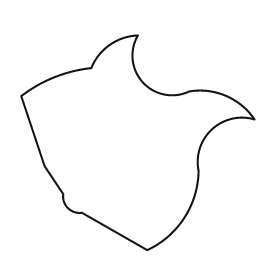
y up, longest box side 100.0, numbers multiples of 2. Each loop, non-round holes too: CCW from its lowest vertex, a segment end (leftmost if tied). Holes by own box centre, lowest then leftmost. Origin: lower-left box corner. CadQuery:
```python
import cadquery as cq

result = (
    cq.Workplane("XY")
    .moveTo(54.0, 0.0)
    .threePointArc((70.0, 14.0), (76.0, 34.0))
    .threePointArc((82.0, 52.0), (100.0, 56.0))
    .threePointArc((88.0, 66.0), (72.0, 68.0))
    .threePointArc((52.0, 72.0), (50.0, 92.0))
    .threePointArc((38.0, 88.0), (30.0, 78.0))
    .threePointArc((14.0, 74.0), (0.0, 66.0))
    .lineTo(10.0, 36.0)
    .lineTo(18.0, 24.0)
    .threePointArc((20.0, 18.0), (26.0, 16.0))
    .close()
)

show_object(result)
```